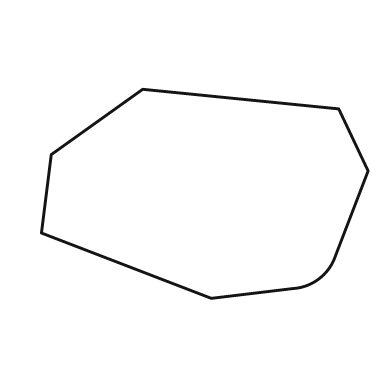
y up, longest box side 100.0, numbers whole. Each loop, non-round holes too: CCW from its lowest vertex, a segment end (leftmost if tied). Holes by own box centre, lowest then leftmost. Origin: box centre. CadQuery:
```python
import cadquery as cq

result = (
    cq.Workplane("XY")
    .moveTo(2.0, -32.0)
    .lineTo(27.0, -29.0)
    .threePointArc((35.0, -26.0), (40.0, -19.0))
    .lineTo(50.0, 7.0)
    .lineTo(41.0, 26.0)
    .lineTo(-19.0, 32.0)
    .lineTo(-47.0, 12.0)
    .lineTo(-50.0, -12.0)
    .close()
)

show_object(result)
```